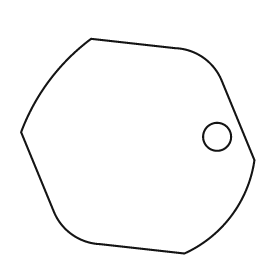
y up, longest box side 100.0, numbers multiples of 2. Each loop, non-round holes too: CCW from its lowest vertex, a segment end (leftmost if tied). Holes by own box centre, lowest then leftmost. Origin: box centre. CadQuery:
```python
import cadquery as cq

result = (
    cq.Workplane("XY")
    .moveTo(20.0, -46.0)
    .threePointArc((40.0, -30.0), (50.0, -6.0))
    .lineTo(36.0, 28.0)
    .threePointArc((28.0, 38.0), (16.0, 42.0))
    .lineTo(-20.0, 46.0)
    .threePointArc((-38.0, 28.0), (-50.0, 6.0))
    .lineTo(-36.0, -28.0)
    .threePointArc((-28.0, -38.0), (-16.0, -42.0))
    .close()
    .moveTo(34.0, 4.0)
    .circle(6.0)
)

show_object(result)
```